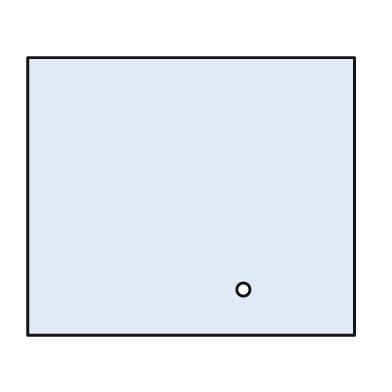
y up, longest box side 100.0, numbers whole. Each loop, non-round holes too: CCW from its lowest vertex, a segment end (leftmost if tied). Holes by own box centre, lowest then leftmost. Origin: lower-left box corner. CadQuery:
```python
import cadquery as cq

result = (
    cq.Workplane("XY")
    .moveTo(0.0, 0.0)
    .lineTo(100.0, 0.0)
    .lineTo(100.0, 85.0)
    .lineTo(0.0, 85.0)
    .close()
    .moveTo(66.0, 14.0)
    .circle(2.0)
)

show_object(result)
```